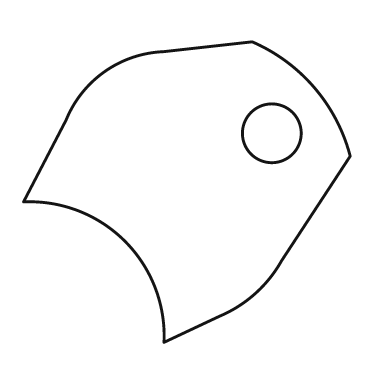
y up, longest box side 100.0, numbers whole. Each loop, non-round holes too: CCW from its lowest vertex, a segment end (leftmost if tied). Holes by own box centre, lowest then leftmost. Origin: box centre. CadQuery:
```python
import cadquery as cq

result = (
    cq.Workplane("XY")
    .moveTo(-7.0, -46.0)
    .lineTo(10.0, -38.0)
    .threePointArc((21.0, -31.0), (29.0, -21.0))
    .lineTo(50.0, 11.0)
    .threePointArc((39.0, 32.0), (20.0, 46.0))
    .lineTo(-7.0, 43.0)
    .threePointArc((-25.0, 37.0), (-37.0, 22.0))
    .lineTo(-50.0, -3.0)
    .threePointArc((-19.0, -15.0), (-7.0, -46.0))
    .close()
    .moveTo(26.0, 18.0)
    .circle(9.0)
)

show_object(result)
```